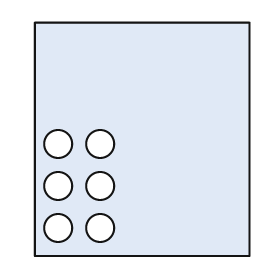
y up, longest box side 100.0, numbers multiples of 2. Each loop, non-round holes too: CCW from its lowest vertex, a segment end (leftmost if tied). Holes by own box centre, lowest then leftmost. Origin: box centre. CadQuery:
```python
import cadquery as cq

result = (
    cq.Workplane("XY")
    .moveTo(-46.0, -50.0)
    .lineTo(46.0, -50.0)
    .lineTo(46.0, 50.0)
    .lineTo(-46.0, 50.0)
    .close()
    .moveTo(-36.0, -38.0)
    .circle(6.0)
    .moveTo(-18.0, -38.0)
    .circle(6.0)
    .moveTo(-36.0, -20.0)
    .circle(6.0)
    .moveTo(-18.0, -20.0)
    .circle(6.0)
    .moveTo(-36.0, -2.0)
    .circle(6.0)
    .moveTo(-18.0, -2.0)
    .circle(6.0)
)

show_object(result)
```